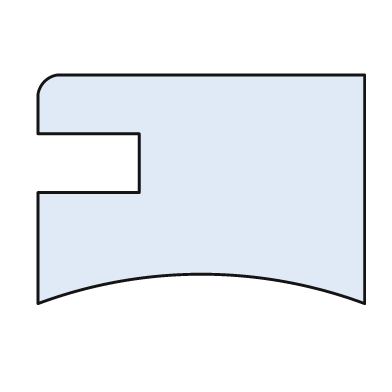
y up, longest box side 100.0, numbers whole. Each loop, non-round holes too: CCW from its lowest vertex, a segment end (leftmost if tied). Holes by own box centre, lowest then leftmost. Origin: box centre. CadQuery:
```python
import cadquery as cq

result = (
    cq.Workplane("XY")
    .moveTo(-50.0, -35.0)
    .threePointArc((0.0, -26.0), (50.0, -35.0))
    .lineTo(50.0, 35.0)
    .lineTo(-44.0, 35.0)
    .threePointArc((-48.0, 33.0), (-50.0, 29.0))
    .lineTo(-50.0, 17.0)
    .lineTo(-19.0, 17.0)
    .lineTo(-19.0, -1.0)
    .lineTo(-50.0, -1.0)
    .close()
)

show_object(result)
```